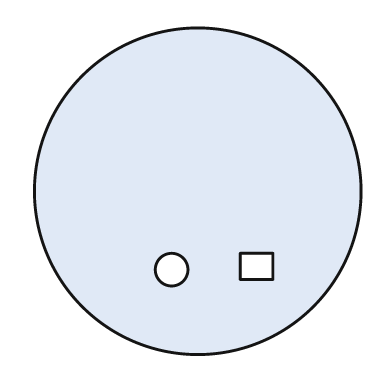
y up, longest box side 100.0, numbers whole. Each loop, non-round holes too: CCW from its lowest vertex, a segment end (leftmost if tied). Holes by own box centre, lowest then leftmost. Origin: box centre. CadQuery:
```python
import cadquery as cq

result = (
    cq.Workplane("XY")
    .moveTo(0.0, 0.0)
    .circle(50.0)
    .moveTo(-8.0, -24.0)
    .circle(5.0)
    .moveTo(13.0, -27.0)
    .lineTo(23.0, -27.0)
    .lineTo(23.0, -19.0)
    .lineTo(13.0, -19.0)
    .close()
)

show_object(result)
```